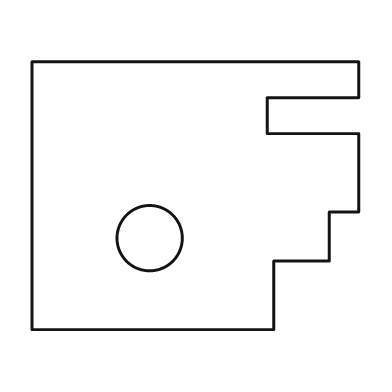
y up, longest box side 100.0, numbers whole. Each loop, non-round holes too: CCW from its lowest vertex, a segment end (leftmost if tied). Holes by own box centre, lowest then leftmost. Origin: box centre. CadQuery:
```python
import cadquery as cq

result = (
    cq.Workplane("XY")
    .moveTo(-50.0, -41.0)
    .lineTo(24.0, -41.0)
    .lineTo(24.0, -20.0)
    .lineTo(41.0, -20.0)
    .lineTo(41.0, -5.0)
    .lineTo(50.0, -5.0)
    .lineTo(50.0, 19.0)
    .lineTo(22.0, 19.0)
    .lineTo(22.0, 30.0)
    .lineTo(50.0, 30.0)
    .lineTo(50.0, 41.0)
    .lineTo(-50.0, 41.0)
    .close()
    .moveTo(-14.0, -13.0)
    .circle(10.0)
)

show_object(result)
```